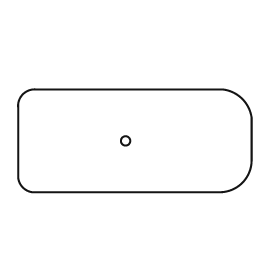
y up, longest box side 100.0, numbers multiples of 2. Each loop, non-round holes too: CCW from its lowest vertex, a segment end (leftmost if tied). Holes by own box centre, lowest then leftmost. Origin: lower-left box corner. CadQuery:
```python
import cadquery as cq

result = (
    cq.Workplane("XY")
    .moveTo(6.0, 0.0)
    .lineTo(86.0, 0.0)
    .threePointArc((96.0, 4.0), (100.0, 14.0))
    .lineTo(100.0, 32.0)
    .threePointArc((96.0, 40.0), (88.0, 44.0))
    .lineTo(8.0, 44.0)
    .threePointArc((2.0, 42.0), (0.0, 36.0))
    .lineTo(0.0, 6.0)
    .threePointArc((2.0, 2.0), (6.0, 0.0))
    .close()
    .moveTo(46.0, 22.0)
    .circle(2.0)
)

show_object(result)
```